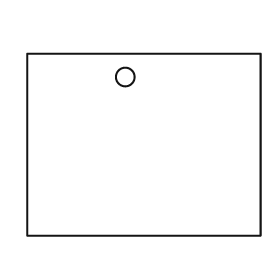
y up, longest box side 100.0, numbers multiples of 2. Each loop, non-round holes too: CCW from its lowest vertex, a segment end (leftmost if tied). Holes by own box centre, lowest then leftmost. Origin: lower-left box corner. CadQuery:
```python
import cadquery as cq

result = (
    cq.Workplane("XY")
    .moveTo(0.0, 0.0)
    .lineTo(100.0, 0.0)
    .lineTo(100.0, 78.0)
    .lineTo(0.0, 78.0)
    .close()
    .moveTo(42.0, 68.0)
    .circle(4.0)
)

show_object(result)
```